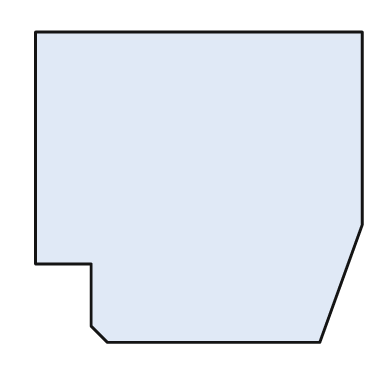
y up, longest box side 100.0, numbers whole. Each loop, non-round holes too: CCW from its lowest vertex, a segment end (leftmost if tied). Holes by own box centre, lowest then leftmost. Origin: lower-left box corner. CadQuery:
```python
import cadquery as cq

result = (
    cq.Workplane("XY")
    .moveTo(22.0, 0.0)
    .lineTo(87.0, 0.0)
    .lineTo(100.0, 36.0)
    .lineTo(100.0, 95.0)
    .lineTo(0.0, 95.0)
    .lineTo(0.0, 24.0)
    .lineTo(17.0, 24.0)
    .lineTo(17.0, 5.0)
    .close()
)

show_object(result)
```